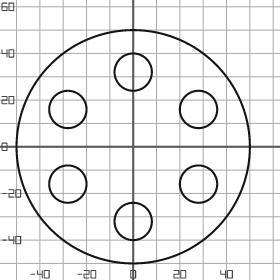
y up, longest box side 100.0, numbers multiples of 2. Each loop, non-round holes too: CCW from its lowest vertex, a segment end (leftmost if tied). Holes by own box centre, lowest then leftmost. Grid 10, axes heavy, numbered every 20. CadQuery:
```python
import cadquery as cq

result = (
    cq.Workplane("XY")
    .moveTo(0.0, 0.0)
    .circle(50.0)
    .moveTo(0.0, -32.0)
    .circle(8.0)
    .moveTo(-28.0, -16.0)
    .circle(8.0)
    .moveTo(28.0, -16.0)
    .circle(8.0)
    .moveTo(-28.0, 16.0)
    .circle(8.0)
    .moveTo(28.0, 16.0)
    .circle(8.0)
    .moveTo(0.0, 32.0)
    .circle(8.0)
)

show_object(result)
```